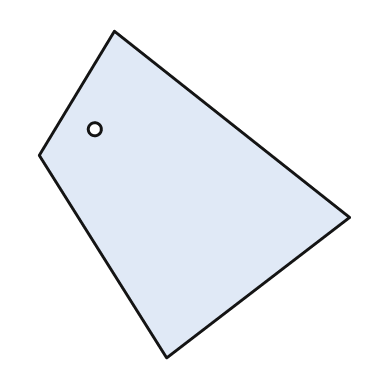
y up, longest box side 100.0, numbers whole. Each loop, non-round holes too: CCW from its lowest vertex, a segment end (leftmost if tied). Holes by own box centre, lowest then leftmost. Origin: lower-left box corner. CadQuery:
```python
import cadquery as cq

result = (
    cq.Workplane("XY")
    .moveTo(39.0, 0.0)
    .lineTo(95.0, 43.0)
    .lineTo(23.0, 100.0)
    .lineTo(0.0, 62.0)
    .close()
    .moveTo(17.0, 70.0)
    .circle(2.0)
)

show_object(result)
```